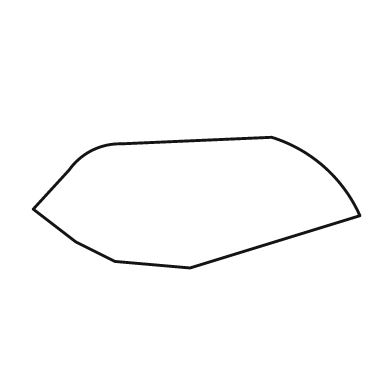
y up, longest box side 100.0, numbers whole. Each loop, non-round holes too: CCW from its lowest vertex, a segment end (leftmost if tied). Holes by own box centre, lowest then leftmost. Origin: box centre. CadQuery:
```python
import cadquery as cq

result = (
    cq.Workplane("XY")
    .moveTo(-2.0, -20.0)
    .lineTo(50.0, -4.0)
    .threePointArc((39.0, 11.0), (23.0, 20.0))
    .lineTo(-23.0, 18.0)
    .threePointArc((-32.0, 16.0), (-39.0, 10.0))
    .lineTo(-50.0, -2.0)
    .lineTo(-37.0, -12.0)
    .lineTo(-25.0, -18.0)
    .close()
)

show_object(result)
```